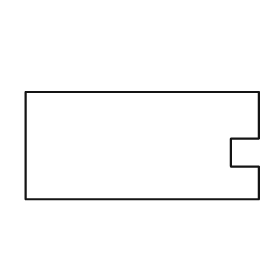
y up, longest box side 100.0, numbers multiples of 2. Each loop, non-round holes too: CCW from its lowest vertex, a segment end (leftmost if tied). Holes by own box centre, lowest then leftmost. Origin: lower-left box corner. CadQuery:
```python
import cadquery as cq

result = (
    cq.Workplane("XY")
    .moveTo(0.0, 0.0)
    .lineTo(100.0, 0.0)
    .lineTo(100.0, 14.0)
    .lineTo(88.0, 14.0)
    .lineTo(88.0, 26.0)
    .lineTo(100.0, 26.0)
    .lineTo(100.0, 46.0)
    .lineTo(0.0, 46.0)
    .close()
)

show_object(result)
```